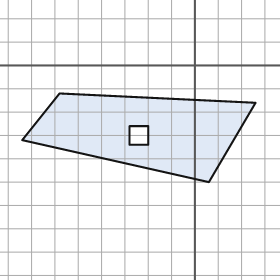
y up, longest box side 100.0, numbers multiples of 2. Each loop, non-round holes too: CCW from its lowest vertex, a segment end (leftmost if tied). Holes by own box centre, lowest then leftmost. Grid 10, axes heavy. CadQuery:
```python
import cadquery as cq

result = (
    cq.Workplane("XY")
    .moveTo(6.0, -50.0)
    .lineTo(26.0, -16.0)
    .lineTo(-58.0, -12.0)
    .lineTo(-74.0, -32.0)
    .close()
    .moveTo(-28.0, -34.0)
    .lineTo(-20.0, -34.0)
    .lineTo(-20.0, -26.0)
    .lineTo(-28.0, -26.0)
    .close()
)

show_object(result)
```